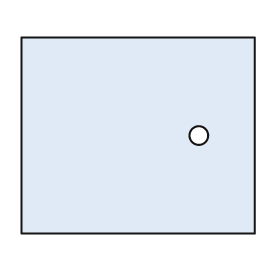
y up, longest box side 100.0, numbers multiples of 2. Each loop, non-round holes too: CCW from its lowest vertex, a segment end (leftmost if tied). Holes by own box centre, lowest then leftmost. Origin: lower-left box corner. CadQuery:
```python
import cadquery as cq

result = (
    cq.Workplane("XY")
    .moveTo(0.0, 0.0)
    .lineTo(100.0, 0.0)
    .lineTo(100.0, 84.0)
    .lineTo(0.0, 84.0)
    .close()
    .moveTo(76.0, 42.0)
    .circle(4.0)
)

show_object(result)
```